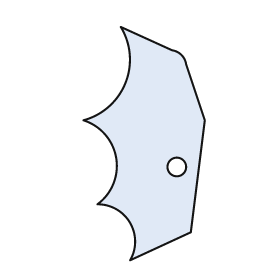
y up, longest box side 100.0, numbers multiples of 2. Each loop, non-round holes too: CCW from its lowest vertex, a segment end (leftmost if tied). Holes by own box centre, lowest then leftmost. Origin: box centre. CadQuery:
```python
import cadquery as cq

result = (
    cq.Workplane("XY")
    .moveTo(-6.0, -50.0)
    .lineTo(20.0, -38.0)
    .lineTo(26.0, 10.0)
    .lineTo(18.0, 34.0)
    .threePointArc((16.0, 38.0), (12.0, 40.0))
    .lineTo(-10.0, 50.0)
    .threePointArc((-8.0, 26.0), (-26.0, 10.0))
    .threePointArc((-12.0, -6.0), (-20.0, -26.0))
    .threePointArc((-6.0, -34.0), (-6.0, -50.0))
    .close()
    .moveTo(14.0, -10.0)
    .circle(4.0)
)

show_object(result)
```